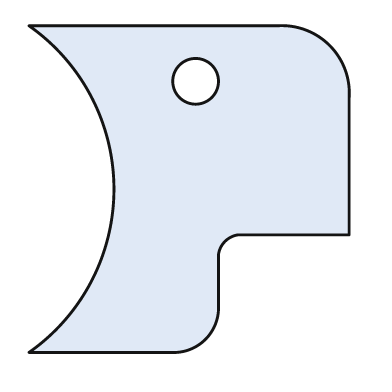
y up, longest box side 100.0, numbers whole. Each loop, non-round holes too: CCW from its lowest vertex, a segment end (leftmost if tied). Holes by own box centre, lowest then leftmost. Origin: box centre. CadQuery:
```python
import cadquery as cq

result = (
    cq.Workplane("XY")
    .moveTo(-49.0, -50.0)
    .lineTo(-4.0, -50.0)
    .threePointArc((5.0, -46.0), (9.0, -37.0))
    .lineTo(9.0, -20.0)
    .threePointArc((11.0, -16.0), (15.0, -14.0))
    .lineTo(49.0, -14.0)
    .lineTo(49.0, 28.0)
    .threePointArc((43.0, 44.0), (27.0, 50.0))
    .lineTo(-49.0, 50.0)
    .threePointArc((-23.0, 0.0), (-49.0, -50.0))
    .close()
    .moveTo(2.0, 33.0)
    .circle(7.0)
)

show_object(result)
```